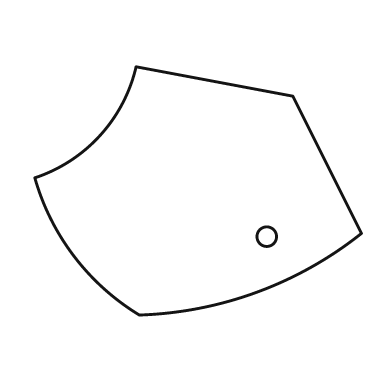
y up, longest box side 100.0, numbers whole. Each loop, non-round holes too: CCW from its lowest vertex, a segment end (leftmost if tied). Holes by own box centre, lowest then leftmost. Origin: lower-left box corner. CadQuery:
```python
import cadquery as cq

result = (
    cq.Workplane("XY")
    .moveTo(32.0, 0.0)
    .threePointArc((68.0, 7.0), (100.0, 25.0))
    .lineTo(79.0, 67.0)
    .lineTo(31.0, 76.0)
    .threePointArc((20.0, 55.0), (0.0, 42.0))
    .threePointArc((12.0, 18.0), (32.0, 0.0))
    .close()
    .moveTo(71.0, 24.0)
    .circle(3.0)
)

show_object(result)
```